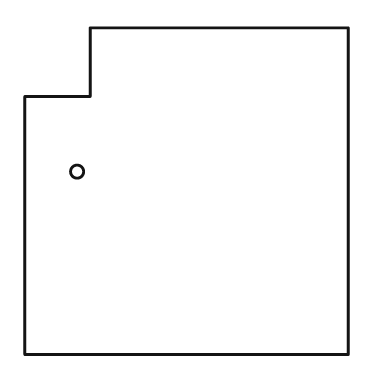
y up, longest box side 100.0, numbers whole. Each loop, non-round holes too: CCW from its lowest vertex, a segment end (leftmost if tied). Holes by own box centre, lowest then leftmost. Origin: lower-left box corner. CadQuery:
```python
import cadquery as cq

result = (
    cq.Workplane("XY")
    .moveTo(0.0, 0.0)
    .lineTo(99.0, 0.0)
    .lineTo(99.0, 100.0)
    .lineTo(20.0, 100.0)
    .lineTo(20.0, 79.0)
    .lineTo(0.0, 79.0)
    .close()
    .moveTo(16.0, 56.0)
    .circle(2.0)
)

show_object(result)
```